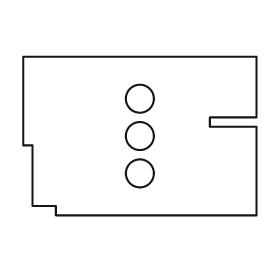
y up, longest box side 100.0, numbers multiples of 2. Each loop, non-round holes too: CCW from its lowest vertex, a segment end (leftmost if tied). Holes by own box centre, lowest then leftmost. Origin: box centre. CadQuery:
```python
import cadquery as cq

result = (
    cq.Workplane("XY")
    .moveTo(-36.0, -34.0)
    .lineTo(50.0, -34.0)
    .lineTo(50.0, 4.0)
    .lineTo(30.0, 4.0)
    .lineTo(30.0, 8.0)
    .lineTo(50.0, 8.0)
    .lineTo(50.0, 34.0)
    .lineTo(-50.0, 34.0)
    .lineTo(-50.0, -4.0)
    .lineTo(-46.0, -4.0)
    .lineTo(-46.0, -30.0)
    .lineTo(-36.0, -30.0)
    .close()
    .moveTo(0.0, -16.0)
    .circle(6.0)
    .moveTo(0.0, 0.0)
    .circle(6.0)
    .moveTo(0.0, 16.0)
    .circle(6.0)
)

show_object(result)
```